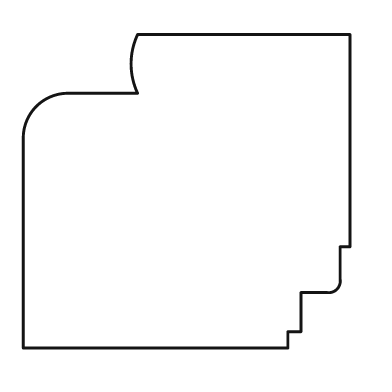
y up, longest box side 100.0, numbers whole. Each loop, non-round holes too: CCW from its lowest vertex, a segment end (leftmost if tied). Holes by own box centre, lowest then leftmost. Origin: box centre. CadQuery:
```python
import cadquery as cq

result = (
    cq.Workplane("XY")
    .moveTo(-50.0, -48.0)
    .lineTo(31.0, -48.0)
    .lineTo(31.0, -43.0)
    .lineTo(35.0, -43.0)
    .lineTo(35.0, -31.0)
    .lineTo(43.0, -31.0)
    .threePointArc((46.0, -30.0), (47.0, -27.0))
    .lineTo(47.0, -17.0)
    .lineTo(50.0, -17.0)
    .lineTo(50.0, 48.0)
    .lineTo(-15.0, 48.0)
    .threePointArc((-17.0, 39.0), (-15.0, 30.0))
    .lineTo(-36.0, 30.0)
    .threePointArc((-46.0, 26.0), (-50.0, 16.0))
    .close()
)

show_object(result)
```